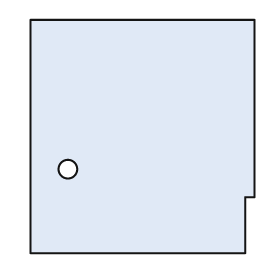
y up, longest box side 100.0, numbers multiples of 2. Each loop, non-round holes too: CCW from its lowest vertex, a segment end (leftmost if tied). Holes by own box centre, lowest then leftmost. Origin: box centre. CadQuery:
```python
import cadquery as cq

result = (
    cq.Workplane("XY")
    .moveTo(-48.0, -50.0)
    .lineTo(44.0, -50.0)
    .lineTo(44.0, -26.0)
    .lineTo(48.0, -26.0)
    .lineTo(48.0, 50.0)
    .lineTo(-48.0, 50.0)
    .close()
    .moveTo(-32.0, -14.0)
    .circle(4.0)
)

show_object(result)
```